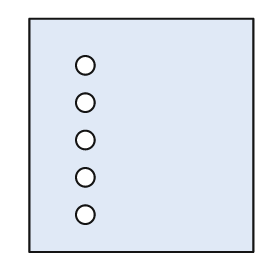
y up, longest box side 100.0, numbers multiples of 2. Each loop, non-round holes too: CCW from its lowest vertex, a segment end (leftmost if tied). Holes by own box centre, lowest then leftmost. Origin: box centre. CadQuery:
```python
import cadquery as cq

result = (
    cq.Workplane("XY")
    .moveTo(-48.0, -50.0)
    .lineTo(48.0, -50.0)
    .lineTo(48.0, 50.0)
    .lineTo(-48.0, 50.0)
    .close()
    .moveTo(-24.0, -34.0)
    .circle(4.0)
    .moveTo(-24.0, -18.0)
    .circle(4.0)
    .moveTo(-24.0, -2.0)
    .circle(4.0)
    .moveTo(-24.0, 14.0)
    .circle(4.0)
    .moveTo(-24.0, 30.0)
    .circle(4.0)
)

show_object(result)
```